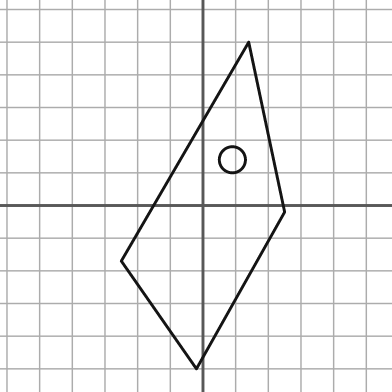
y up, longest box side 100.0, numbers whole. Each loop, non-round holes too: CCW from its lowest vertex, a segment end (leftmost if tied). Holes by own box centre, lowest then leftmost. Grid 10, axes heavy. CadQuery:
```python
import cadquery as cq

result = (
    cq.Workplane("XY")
    .moveTo(-2.0, -50.0)
    .lineTo(25.0, -2.0)
    .lineTo(14.0, 50.0)
    .lineTo(-25.0, -17.0)
    .close()
    .moveTo(9.0, 14.0)
    .circle(4.0)
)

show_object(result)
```